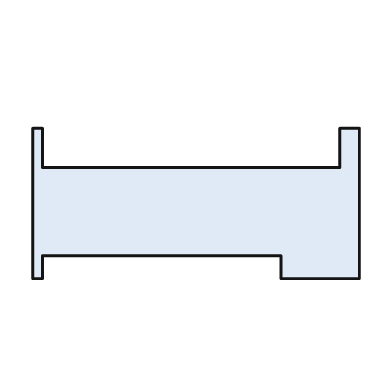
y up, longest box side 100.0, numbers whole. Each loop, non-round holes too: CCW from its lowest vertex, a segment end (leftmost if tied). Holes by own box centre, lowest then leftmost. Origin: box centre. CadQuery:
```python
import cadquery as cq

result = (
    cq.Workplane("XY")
    .moveTo(-50.0, -23.0)
    .lineTo(-47.0, -23.0)
    .lineTo(-47.0, -16.0)
    .lineTo(26.0, -16.0)
    .lineTo(26.0, -23.0)
    .lineTo(50.0, -23.0)
    .lineTo(50.0, 23.0)
    .lineTo(44.0, 23.0)
    .lineTo(44.0, 11.0)
    .lineTo(-47.0, 11.0)
    .lineTo(-47.0, 23.0)
    .lineTo(-50.0, 23.0)
    .close()
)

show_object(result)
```